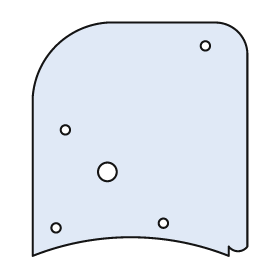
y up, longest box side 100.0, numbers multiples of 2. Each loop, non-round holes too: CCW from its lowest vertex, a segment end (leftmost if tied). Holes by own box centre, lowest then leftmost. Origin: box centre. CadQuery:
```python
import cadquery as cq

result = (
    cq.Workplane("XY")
    .moveTo(-46.0, -50.0)
    .threePointArc((-4.0, -42.0), (38.0, -50.0))
    .lineTo(38.0, -46.0)
    .threePointArc((42.0, -48.0), (46.0, -46.0))
    .lineTo(46.0, 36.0)
    .threePointArc((42.0, 46.0), (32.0, 50.0))
    .lineTo(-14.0, 50.0)
    .threePointArc((-36.0, 40.0), (-46.0, 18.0))
    .close()
    .moveTo(-36.0, -38.0)
    .circle(2.0)
    .moveTo(10.0, -36.0)
    .circle(2.0)
    .moveTo(-14.0, -14.0)
    .circle(4.0)
    .moveTo(-32.0, 4.0)
    .circle(2.0)
    .moveTo(28.0, 40.0)
    .circle(2.0)
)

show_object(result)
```